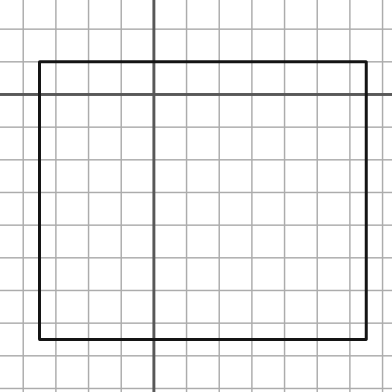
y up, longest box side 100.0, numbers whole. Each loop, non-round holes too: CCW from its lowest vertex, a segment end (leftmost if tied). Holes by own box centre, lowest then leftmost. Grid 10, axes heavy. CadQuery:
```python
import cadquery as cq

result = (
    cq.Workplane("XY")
    .moveTo(-35.0, -75.0)
    .lineTo(65.0, -75.0)
    .lineTo(65.0, 10.0)
    .lineTo(-35.0, 10.0)
    .close()
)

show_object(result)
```